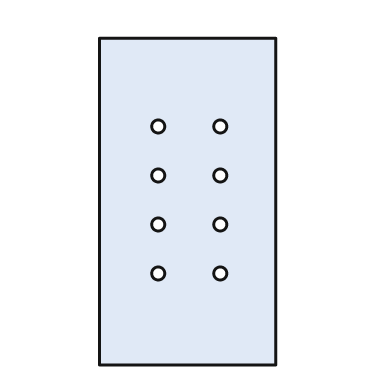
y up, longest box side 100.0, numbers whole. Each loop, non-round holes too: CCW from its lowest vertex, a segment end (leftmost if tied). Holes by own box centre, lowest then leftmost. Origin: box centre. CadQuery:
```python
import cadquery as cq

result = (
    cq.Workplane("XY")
    .moveTo(-27.0, -50.0)
    .lineTo(27.0, -50.0)
    .lineTo(27.0, 50.0)
    .lineTo(-27.0, 50.0)
    .close()
    .moveTo(-9.0, -22.0)
    .circle(2.0)
    .moveTo(10.0, -22.0)
    .circle(2.0)
    .moveTo(-9.0, -7.0)
    .circle(2.0)
    .moveTo(10.0, -7.0)
    .circle(2.0)
    .moveTo(-9.0, 8.0)
    .circle(2.0)
    .moveTo(10.0, 8.0)
    .circle(2.0)
    .moveTo(-9.0, 23.0)
    .circle(2.0)
    .moveTo(10.0, 23.0)
    .circle(2.0)
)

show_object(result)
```